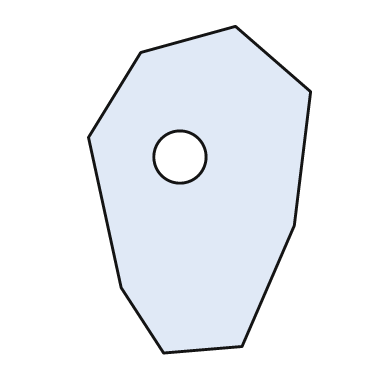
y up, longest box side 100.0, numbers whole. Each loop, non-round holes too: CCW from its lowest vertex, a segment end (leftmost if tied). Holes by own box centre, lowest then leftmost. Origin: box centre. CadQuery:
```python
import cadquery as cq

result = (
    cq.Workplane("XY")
    .moveTo(-11.0, -50.0)
    .lineTo(13.0, -48.0)
    .lineTo(29.0, -11.0)
    .lineTo(34.0, 30.0)
    .lineTo(11.0, 50.0)
    .lineTo(-18.0, 42.0)
    .lineTo(-34.0, 16.0)
    .lineTo(-24.0, -30.0)
    .close()
    .moveTo(-6.0, 10.0)
    .circle(8.0)
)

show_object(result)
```